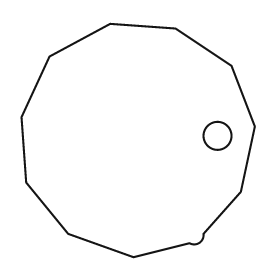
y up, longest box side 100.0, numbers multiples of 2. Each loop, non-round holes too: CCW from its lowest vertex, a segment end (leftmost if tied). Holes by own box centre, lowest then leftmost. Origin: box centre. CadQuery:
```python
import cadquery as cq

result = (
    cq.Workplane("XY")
    .moveTo(-2.0, -50.0)
    .lineTo(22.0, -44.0)
    .threePointArc((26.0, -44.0), (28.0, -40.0))
    .lineTo(44.0, -22.0)
    .lineTo(50.0, 6.0)
    .lineTo(40.0, 32.0)
    .lineTo(16.0, 48.0)
    .lineTo(-12.0, 50.0)
    .lineTo(-38.0, 36.0)
    .lineTo(-50.0, 10.0)
    .lineTo(-48.0, -18.0)
    .lineTo(-30.0, -40.0)
    .close()
    .moveTo(34.0, 2.0)
    .circle(6.0)
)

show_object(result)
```